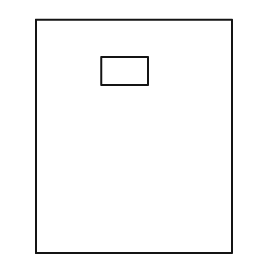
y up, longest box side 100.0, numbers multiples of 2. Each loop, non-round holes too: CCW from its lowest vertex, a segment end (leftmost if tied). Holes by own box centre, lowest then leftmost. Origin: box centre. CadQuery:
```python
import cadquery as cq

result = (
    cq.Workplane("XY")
    .moveTo(-42.0, -50.0)
    .lineTo(42.0, -50.0)
    .lineTo(42.0, 50.0)
    .lineTo(-42.0, 50.0)
    .close()
    .moveTo(-14.0, 22.0)
    .lineTo(6.0, 22.0)
    .lineTo(6.0, 34.0)
    .lineTo(-14.0, 34.0)
    .close()
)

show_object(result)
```